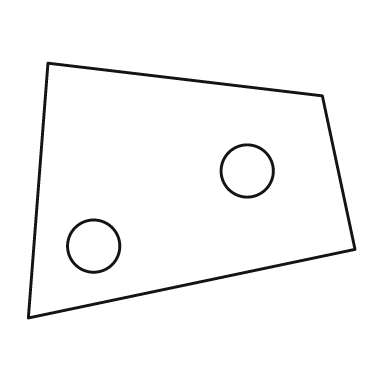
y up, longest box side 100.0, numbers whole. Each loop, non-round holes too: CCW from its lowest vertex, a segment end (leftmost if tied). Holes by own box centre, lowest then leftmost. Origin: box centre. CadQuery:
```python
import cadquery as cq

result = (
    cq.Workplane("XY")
    .moveTo(-50.0, -39.0)
    .lineTo(50.0, -18.0)
    .lineTo(40.0, 29.0)
    .lineTo(-44.0, 39.0)
    .close()
    .moveTo(-30.0, -17.0)
    .circle(8.0)
    .moveTo(17.0, 6.0)
    .circle(8.0)
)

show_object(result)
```